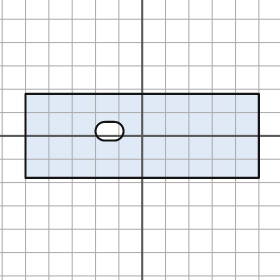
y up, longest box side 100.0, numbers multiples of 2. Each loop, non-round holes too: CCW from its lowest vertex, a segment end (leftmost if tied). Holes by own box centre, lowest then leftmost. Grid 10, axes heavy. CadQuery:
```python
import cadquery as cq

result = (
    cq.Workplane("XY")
    .moveTo(-50.0, -18.0)
    .lineTo(50.0, -18.0)
    .lineTo(50.0, 18.0)
    .lineTo(-50.0, 18.0)
    .close()
    .moveTo(-16.0, -2.0)
    .lineTo(-12.0, -2.0)
    .threePointArc((-8.0, 2.0), (-12.0, 6.0))
    .lineTo(-16.0, 6.0)
    .threePointArc((-20.0, 2.0), (-16.0, -2.0))
    .close()
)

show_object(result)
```